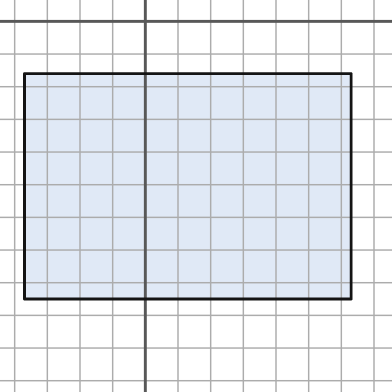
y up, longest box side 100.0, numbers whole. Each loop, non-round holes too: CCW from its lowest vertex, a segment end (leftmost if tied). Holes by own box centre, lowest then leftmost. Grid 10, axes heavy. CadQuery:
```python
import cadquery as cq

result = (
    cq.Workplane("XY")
    .moveTo(-37.0, -85.0)
    .lineTo(63.0, -85.0)
    .lineTo(63.0, -16.0)
    .lineTo(-37.0, -16.0)
    .close()
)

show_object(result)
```